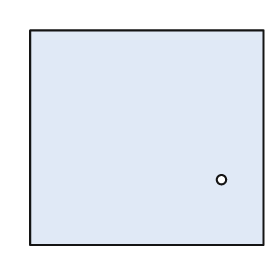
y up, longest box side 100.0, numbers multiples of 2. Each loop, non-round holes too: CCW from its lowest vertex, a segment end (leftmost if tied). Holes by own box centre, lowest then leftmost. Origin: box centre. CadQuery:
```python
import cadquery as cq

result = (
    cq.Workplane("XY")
    .moveTo(-50.0, -46.0)
    .lineTo(50.0, -46.0)
    .lineTo(50.0, 46.0)
    .lineTo(-50.0, 46.0)
    .close()
    .moveTo(32.0, -18.0)
    .circle(2.0)
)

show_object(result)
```